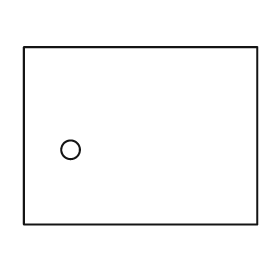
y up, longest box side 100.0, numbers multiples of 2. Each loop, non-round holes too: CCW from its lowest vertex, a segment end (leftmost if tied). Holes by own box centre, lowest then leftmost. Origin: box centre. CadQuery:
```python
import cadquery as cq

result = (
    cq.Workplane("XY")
    .moveTo(-50.0, -38.0)
    .lineTo(50.0, -38.0)
    .lineTo(50.0, 38.0)
    .lineTo(-50.0, 38.0)
    .close()
    .moveTo(-30.0, -6.0)
    .circle(4.0)
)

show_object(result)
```